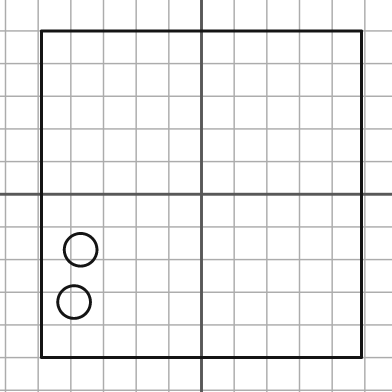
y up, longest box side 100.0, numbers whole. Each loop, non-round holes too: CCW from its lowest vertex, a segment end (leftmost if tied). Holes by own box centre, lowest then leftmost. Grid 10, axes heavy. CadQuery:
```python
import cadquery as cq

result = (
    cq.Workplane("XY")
    .moveTo(-49.0, -50.0)
    .lineTo(49.0, -50.0)
    .lineTo(49.0, 50.0)
    .lineTo(-49.0, 50.0)
    .close()
    .moveTo(-39.0, -33.0)
    .circle(5.0)
    .moveTo(-37.0, -17.0)
    .circle(5.0)
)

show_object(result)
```